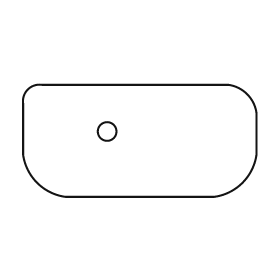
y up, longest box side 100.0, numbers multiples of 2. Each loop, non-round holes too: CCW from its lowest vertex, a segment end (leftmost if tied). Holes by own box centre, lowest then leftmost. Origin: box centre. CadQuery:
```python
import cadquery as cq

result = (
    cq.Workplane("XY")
    .moveTo(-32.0, -24.0)
    .lineTo(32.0, -24.0)
    .threePointArc((44.0, -18.0), (50.0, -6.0))
    .lineTo(50.0, 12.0)
    .threePointArc((46.0, 20.0), (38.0, 24.0))
    .lineTo(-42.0, 24.0)
    .threePointArc((-48.0, 22.0), (-50.0, 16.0))
    .lineTo(-50.0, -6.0)
    .threePointArc((-44.0, -18.0), (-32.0, -24.0))
    .close()
    .moveTo(-14.0, 4.0)
    .circle(4.0)
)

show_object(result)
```